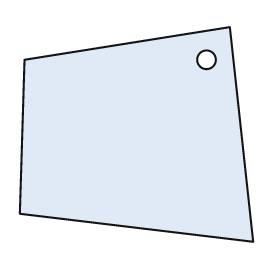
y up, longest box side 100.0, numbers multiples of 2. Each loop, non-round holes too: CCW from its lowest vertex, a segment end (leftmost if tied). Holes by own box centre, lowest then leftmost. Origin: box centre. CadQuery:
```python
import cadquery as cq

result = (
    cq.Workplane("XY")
    .moveTo(50.0, -46.0)
    .lineTo(40.0, 46.0)
    .lineTo(-48.0, 32.0)
    .lineTo(-50.0, -34.0)
    .close()
    .moveTo(30.0, 32.0)
    .circle(4.0)
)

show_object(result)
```